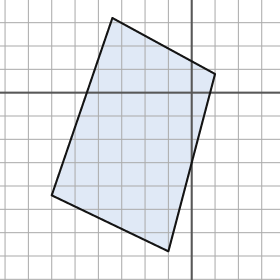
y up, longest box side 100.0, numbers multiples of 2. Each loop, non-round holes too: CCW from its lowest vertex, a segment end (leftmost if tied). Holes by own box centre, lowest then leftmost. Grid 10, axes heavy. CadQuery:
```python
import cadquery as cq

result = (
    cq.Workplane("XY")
    .moveTo(-10.0, -68.0)
    .lineTo(10.0, 8.0)
    .lineTo(-34.0, 32.0)
    .lineTo(-60.0, -44.0)
    .close()
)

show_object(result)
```